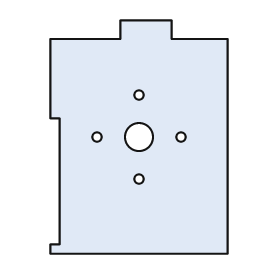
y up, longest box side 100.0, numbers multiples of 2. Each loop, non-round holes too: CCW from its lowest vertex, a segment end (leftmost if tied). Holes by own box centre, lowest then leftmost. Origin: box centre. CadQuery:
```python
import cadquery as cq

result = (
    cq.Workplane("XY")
    .moveTo(-38.0, -50.0)
    .lineTo(38.0, -50.0)
    .lineTo(38.0, 42.0)
    .lineTo(14.0, 42.0)
    .lineTo(14.0, 50.0)
    .lineTo(-8.0, 50.0)
    .lineTo(-8.0, 42.0)
    .lineTo(-38.0, 42.0)
    .lineTo(-38.0, 8.0)
    .lineTo(-34.0, 8.0)
    .lineTo(-34.0, -46.0)
    .lineTo(-38.0, -46.0)
    .close()
    .moveTo(0.0, -18.0)
    .circle(2.0)
    .moveTo(-18.0, 0.0)
    .circle(2.0)
    .moveTo(0.0, 0.0)
    .circle(6.0)
    .moveTo(18.0, 0.0)
    .circle(2.0)
    .moveTo(0.0, 18.0)
    .circle(2.0)
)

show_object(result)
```